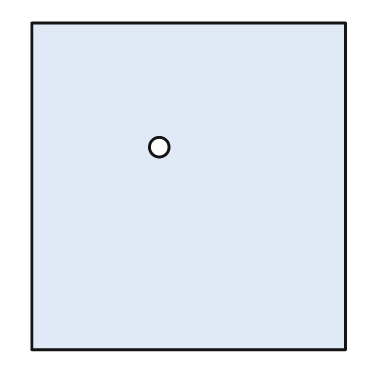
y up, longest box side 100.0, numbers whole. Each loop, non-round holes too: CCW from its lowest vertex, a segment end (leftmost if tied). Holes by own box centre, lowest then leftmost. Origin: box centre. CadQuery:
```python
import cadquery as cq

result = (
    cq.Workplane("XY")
    .moveTo(-48.0, -50.0)
    .lineTo(48.0, -50.0)
    .lineTo(48.0, 50.0)
    .lineTo(-48.0, 50.0)
    .close()
    .moveTo(-9.0, 12.0)
    .circle(3.0)
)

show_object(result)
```